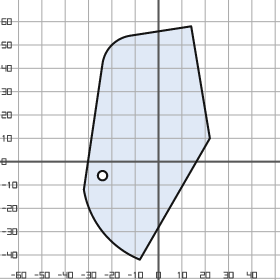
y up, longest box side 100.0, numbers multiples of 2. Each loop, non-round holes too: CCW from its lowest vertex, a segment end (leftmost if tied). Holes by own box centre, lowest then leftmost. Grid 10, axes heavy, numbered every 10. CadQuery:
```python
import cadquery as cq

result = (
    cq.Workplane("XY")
    .moveTo(-8.0, -42.0)
    .lineTo(22.0, 10.0)
    .lineTo(14.0, 58.0)
    .lineTo(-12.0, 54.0)
    .threePointArc((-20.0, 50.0), (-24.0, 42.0))
    .lineTo(-32.0, -12.0)
    .threePointArc((-24.0, -30.0), (-8.0, -42.0))
    .close()
    .moveTo(-24.0, -6.0)
    .circle(2.0)
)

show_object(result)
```